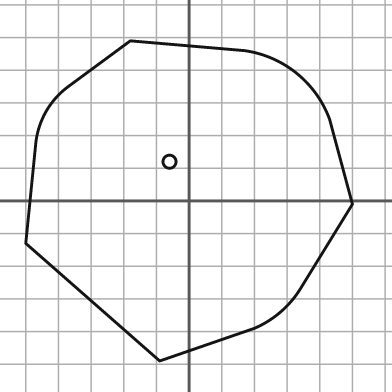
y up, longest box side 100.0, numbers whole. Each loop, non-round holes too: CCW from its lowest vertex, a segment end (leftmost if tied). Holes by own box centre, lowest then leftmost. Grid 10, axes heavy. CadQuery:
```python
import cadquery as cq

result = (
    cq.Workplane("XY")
    .moveTo(-9.0, -49.0)
    .lineTo(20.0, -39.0)
    .threePointArc((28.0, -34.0), (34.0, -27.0))
    .lineTo(50.0, -1.0)
    .lineTo(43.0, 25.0)
    .threePointArc((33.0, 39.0), (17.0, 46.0))
    .lineTo(-18.0, 49.0)
    .lineTo(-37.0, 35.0)
    .threePointArc((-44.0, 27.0), (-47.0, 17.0))
    .lineTo(-50.0, -13.0)
    .close()
    .moveTo(-6.0, 12.0)
    .circle(2.0)
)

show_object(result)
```